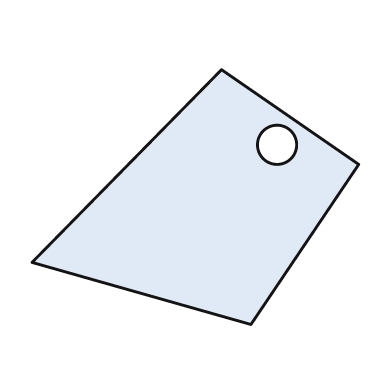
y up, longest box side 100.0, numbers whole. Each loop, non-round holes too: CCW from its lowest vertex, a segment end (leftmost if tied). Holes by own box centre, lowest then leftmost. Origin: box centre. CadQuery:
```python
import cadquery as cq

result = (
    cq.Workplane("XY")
    .moveTo(17.0, -39.0)
    .lineTo(50.0, 10.0)
    .lineTo(8.0, 39.0)
    .lineTo(-50.0, -20.0)
    .close()
    .moveTo(25.0, 16.0)
    .circle(6.0)
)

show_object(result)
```